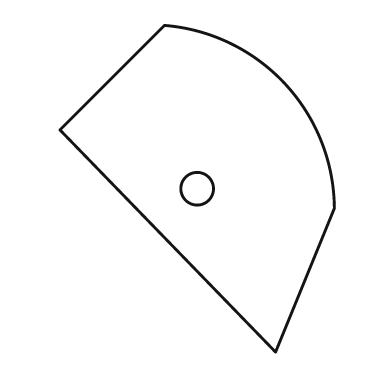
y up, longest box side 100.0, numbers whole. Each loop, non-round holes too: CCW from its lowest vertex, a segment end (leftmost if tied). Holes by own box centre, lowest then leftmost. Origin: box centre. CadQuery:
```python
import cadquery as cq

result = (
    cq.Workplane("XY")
    .moveTo(24.0, -50.0)
    .lineTo(42.0, -6.0)
    .threePointArc((27.0, 32.0), (-10.0, 50.0))
    .lineTo(-42.0, 18.0)
    .close()
    .moveTo(0.0, 0.0)
    .circle(5.0)
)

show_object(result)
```